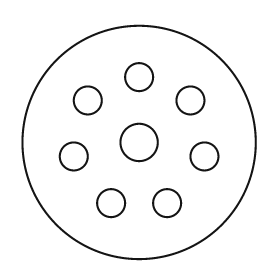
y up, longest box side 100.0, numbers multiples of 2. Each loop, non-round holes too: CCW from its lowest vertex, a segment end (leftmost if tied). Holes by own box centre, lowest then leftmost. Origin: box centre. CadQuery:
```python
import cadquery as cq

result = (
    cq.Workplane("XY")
    .moveTo(0.0, 0.0)
    .circle(50.0)
    .moveTo(-12.0, -26.0)
    .circle(6.0)
    .moveTo(12.0, -26.0)
    .circle(6.0)
    .moveTo(-28.0, -6.0)
    .circle(6.0)
    .moveTo(28.0, -6.0)
    .circle(6.0)
    .moveTo(0.0, 0.0)
    .circle(8.0)
    .moveTo(-22.0, 18.0)
    .circle(6.0)
    .moveTo(22.0, 18.0)
    .circle(6.0)
    .moveTo(0.0, 28.0)
    .circle(6.0)
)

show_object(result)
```